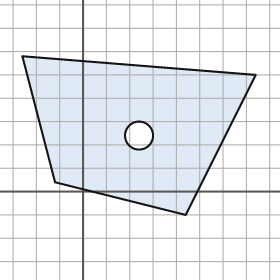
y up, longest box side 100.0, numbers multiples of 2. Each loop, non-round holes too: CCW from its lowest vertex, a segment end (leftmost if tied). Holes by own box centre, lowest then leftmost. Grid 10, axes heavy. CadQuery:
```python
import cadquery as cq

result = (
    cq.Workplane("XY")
    .moveTo(44.0, -10.0)
    .lineTo(74.0, 50.0)
    .lineTo(-26.0, 58.0)
    .lineTo(-12.0, 4.0)
    .close()
    .moveTo(24.0, 24.0)
    .circle(6.0)
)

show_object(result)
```